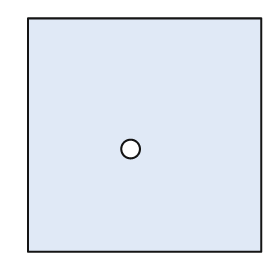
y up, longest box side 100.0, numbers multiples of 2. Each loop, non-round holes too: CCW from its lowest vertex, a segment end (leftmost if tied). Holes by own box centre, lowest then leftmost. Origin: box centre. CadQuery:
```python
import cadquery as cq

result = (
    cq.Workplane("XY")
    .moveTo(-50.0, -50.0)
    .lineTo(50.0, -50.0)
    .lineTo(50.0, 50.0)
    .lineTo(-50.0, 50.0)
    .close()
    .moveTo(-6.0, -6.0)
    .circle(4.0)
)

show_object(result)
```